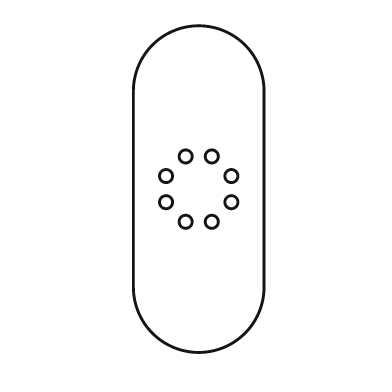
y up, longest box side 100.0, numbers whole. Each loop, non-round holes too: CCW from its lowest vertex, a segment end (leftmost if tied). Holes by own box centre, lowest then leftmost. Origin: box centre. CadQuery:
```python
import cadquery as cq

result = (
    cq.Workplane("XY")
    .moveTo(-20.0, -30.0)
    .threePointArc((0.0, -50.0), (20.0, -30.0))
    .lineTo(20.0, 30.0)
    .threePointArc((0.0, 50.0), (-20.0, 30.0))
    .close()
    .moveTo(-4.0, -10.0)
    .circle(2.0)
    .moveTo(4.0, -10.0)
    .circle(2.0)
    .moveTo(-10.0, -4.0)
    .circle(2.0)
    .moveTo(10.0, -4.0)
    .circle(2.0)
    .moveTo(-10.0, 4.0)
    .circle(2.0)
    .moveTo(10.0, 4.0)
    .circle(2.0)
    .moveTo(-4.0, 10.0)
    .circle(2.0)
    .moveTo(4.0, 10.0)
    .circle(2.0)
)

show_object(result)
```